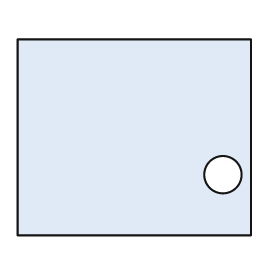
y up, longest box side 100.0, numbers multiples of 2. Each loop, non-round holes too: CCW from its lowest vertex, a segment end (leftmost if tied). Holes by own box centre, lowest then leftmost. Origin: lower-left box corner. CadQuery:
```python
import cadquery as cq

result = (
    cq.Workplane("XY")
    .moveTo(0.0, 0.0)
    .lineTo(100.0, 0.0)
    .lineTo(100.0, 84.0)
    .lineTo(0.0, 84.0)
    .close()
    .moveTo(88.0, 26.0)
    .circle(8.0)
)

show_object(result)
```